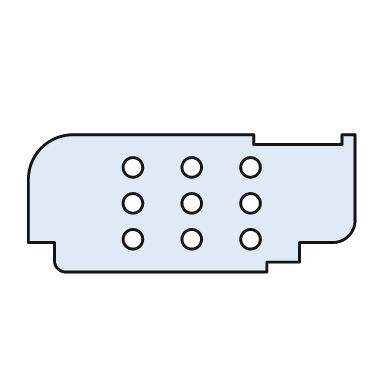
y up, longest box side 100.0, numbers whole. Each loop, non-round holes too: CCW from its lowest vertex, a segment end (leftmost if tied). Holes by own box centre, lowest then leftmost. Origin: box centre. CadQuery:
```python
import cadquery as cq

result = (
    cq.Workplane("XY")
    .moveTo(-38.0, -21.0)
    .lineTo(23.0, -21.0)
    .lineTo(23.0, -18.0)
    .lineTo(33.0, -18.0)
    .lineTo(33.0, -12.0)
    .lineTo(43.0, -12.0)
    .threePointArc((48.0, -10.0), (50.0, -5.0))
    .lineTo(50.0, 21.0)
    .lineTo(46.0, 21.0)
    .lineTo(46.0, 18.0)
    .lineTo(19.0, 18.0)
    .lineTo(19.0, 21.0)
    .lineTo(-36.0, 21.0)
    .threePointArc((-46.0, 17.0), (-50.0, 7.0))
    .lineTo(-50.0, -12.0)
    .lineTo(-42.0, -12.0)
    .lineTo(-42.0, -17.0)
    .threePointArc((-41.0, -20.0), (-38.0, -21.0))
    .close()
    .moveTo(-18.0, -11.0)
    .circle(3.0)
    .moveTo(0.0, -11.0)
    .circle(3.0)
    .moveTo(18.0, -11.0)
    .circle(3.0)
    .moveTo(-18.0, 0.0)
    .circle(3.0)
    .moveTo(0.0, 0.0)
    .circle(3.0)
    .moveTo(18.0, 0.0)
    .circle(3.0)
    .moveTo(-18.0, 11.0)
    .circle(3.0)
    .moveTo(0.0, 11.0)
    .circle(3.0)
    .moveTo(18.0, 11.0)
    .circle(3.0)
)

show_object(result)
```